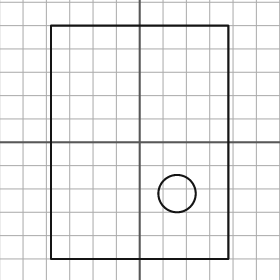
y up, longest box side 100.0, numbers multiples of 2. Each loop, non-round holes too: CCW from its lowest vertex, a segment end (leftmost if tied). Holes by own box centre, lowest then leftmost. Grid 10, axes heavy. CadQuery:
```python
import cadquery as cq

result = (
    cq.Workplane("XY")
    .moveTo(-38.0, -50.0)
    .lineTo(38.0, -50.0)
    .lineTo(38.0, 50.0)
    .lineTo(-38.0, 50.0)
    .close()
    .moveTo(16.0, -22.0)
    .circle(8.0)
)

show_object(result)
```